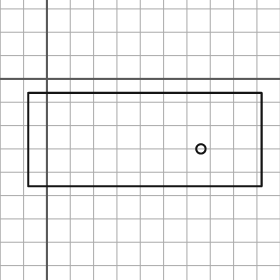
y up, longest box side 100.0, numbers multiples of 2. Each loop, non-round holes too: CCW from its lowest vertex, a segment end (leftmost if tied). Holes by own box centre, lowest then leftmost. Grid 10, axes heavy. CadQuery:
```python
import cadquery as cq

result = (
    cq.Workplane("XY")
    .moveTo(-8.0, -46.0)
    .lineTo(92.0, -46.0)
    .lineTo(92.0, -6.0)
    .lineTo(-8.0, -6.0)
    .close()
    .moveTo(66.0, -30.0)
    .circle(2.0)
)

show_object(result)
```